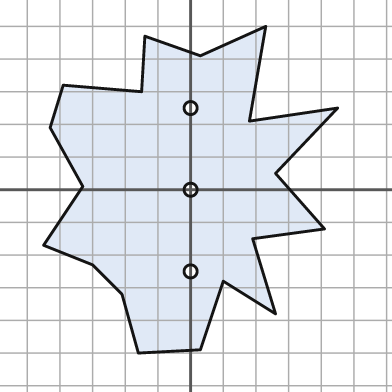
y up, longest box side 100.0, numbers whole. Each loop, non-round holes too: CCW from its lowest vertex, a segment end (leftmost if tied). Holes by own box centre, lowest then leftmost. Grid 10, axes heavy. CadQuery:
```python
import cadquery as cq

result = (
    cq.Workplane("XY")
    .moveTo(-16.0, -50.0)
    .lineTo(3.0, -49.0)
    .lineTo(10.0, -28.0)
    .lineTo(26.0, -38.0)
    .lineTo(19.0, -15.0)
    .lineTo(41.0, -12.0)
    .lineTo(26.0, 5.0)
    .lineTo(45.0, 25.0)
    .lineTo(18.0, 21.0)
    .lineTo(23.0, 50.0)
    .lineTo(3.0, 41.0)
    .lineTo(-14.0, 47.0)
    .lineTo(-15.0, 30.0)
    .lineTo(-39.0, 32.0)
    .lineTo(-43.0, 19.0)
    .lineTo(-33.0, 1.0)
    .lineTo(-45.0, -17.0)
    .lineTo(-30.0, -23.0)
    .lineTo(-21.0, -32.0)
    .close()
    .moveTo(0.0, -25.0)
    .circle(2.0)
    .moveTo(0.0, 0.0)
    .circle(2.0)
    .moveTo(0.0, 25.0)
    .circle(2.0)
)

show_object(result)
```